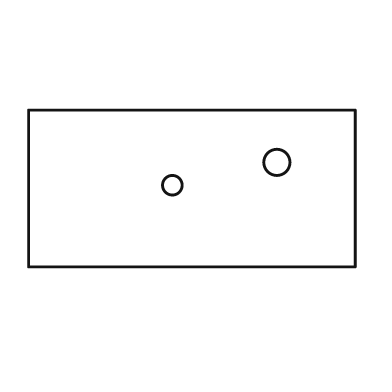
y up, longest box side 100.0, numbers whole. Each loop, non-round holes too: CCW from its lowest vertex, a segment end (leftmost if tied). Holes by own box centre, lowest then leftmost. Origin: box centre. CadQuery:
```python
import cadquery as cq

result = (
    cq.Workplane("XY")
    .moveTo(-50.0, -24.0)
    .lineTo(50.0, -24.0)
    .lineTo(50.0, 24.0)
    .lineTo(-50.0, 24.0)
    .close()
    .moveTo(-6.0, 1.0)
    .circle(3.0)
    .moveTo(26.0, 8.0)
    .circle(4.0)
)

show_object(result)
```